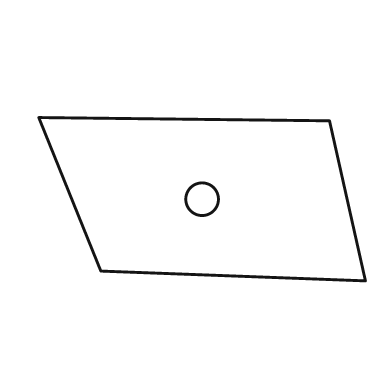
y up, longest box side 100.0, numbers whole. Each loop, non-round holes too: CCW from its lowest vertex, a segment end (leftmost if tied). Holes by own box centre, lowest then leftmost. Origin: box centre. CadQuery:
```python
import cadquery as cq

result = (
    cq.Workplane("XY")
    .moveTo(50.0, -25.0)
    .lineTo(39.0, 24.0)
    .lineTo(-50.0, 25.0)
    .lineTo(-31.0, -22.0)
    .close()
    .moveTo(0.0, 0.0)
    .circle(5.0)
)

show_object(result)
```